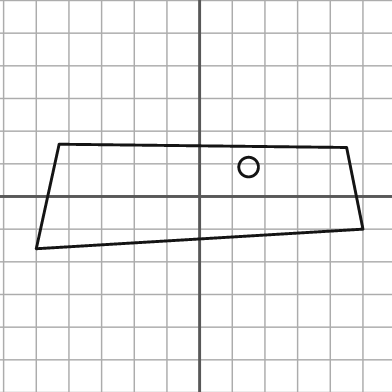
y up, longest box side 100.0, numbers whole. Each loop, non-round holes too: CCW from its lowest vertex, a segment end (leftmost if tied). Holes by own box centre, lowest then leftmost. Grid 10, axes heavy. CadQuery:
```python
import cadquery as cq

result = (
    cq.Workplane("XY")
    .moveTo(-50.0, -16.0)
    .lineTo(50.0, -10.0)
    .lineTo(45.0, 15.0)
    .lineTo(-43.0, 16.0)
    .close()
    .moveTo(15.0, 9.0)
    .circle(3.0)
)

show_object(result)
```